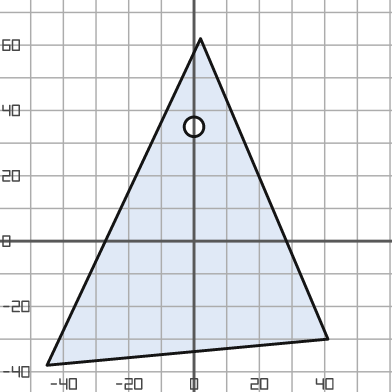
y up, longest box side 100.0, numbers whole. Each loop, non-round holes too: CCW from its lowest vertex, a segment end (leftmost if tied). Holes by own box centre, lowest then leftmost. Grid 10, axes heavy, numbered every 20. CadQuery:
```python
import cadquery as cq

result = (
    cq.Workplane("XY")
    .moveTo(-45.0, -38.0)
    .lineTo(41.0, -30.0)
    .lineTo(2.0, 62.0)
    .close()
    .moveTo(0.0, 35.0)
    .circle(3.0)
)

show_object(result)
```